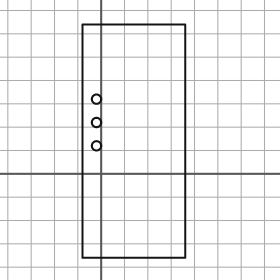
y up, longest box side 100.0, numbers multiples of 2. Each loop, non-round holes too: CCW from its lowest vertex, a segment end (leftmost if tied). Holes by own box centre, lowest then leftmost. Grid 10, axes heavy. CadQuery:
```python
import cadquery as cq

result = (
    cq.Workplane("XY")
    .moveTo(-8.0, -36.0)
    .lineTo(36.0, -36.0)
    .lineTo(36.0, 64.0)
    .lineTo(-8.0, 64.0)
    .close()
    .moveTo(-2.0, 12.0)
    .circle(2.0)
    .moveTo(-2.0, 22.0)
    .circle(2.0)
    .moveTo(-2.0, 32.0)
    .circle(2.0)
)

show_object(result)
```